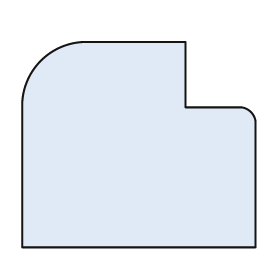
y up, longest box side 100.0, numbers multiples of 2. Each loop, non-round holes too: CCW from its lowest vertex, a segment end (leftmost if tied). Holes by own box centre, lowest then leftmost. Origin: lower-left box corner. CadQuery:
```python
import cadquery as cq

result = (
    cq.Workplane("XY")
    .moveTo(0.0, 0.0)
    .lineTo(100.0, 0.0)
    .lineTo(100.0, 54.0)
    .threePointArc((98.0, 58.0), (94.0, 60.0))
    .lineTo(70.0, 60.0)
    .lineTo(70.0, 88.0)
    .lineTo(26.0, 88.0)
    .threePointArc((8.0, 80.0), (0.0, 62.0))
    .close()
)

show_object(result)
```